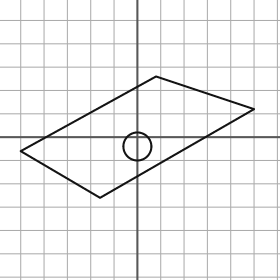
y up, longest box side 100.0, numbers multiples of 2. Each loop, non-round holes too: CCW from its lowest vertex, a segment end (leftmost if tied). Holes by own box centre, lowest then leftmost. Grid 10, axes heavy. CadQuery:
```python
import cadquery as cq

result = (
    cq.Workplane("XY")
    .moveTo(-16.0, -26.0)
    .lineTo(50.0, 12.0)
    .lineTo(8.0, 26.0)
    .lineTo(-50.0, -6.0)
    .close()
    .moveTo(0.0, -4.0)
    .circle(6.0)
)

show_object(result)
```